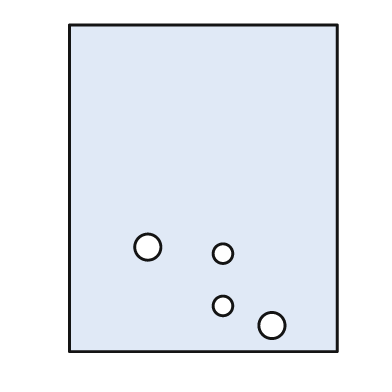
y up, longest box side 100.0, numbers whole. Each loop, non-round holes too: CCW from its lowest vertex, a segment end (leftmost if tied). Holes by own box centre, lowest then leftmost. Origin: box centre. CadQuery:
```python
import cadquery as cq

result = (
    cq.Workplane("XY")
    .moveTo(-41.0, -50.0)
    .lineTo(41.0, -50.0)
    .lineTo(41.0, 50.0)
    .lineTo(-41.0, 50.0)
    .close()
    .moveTo(21.0, -42.0)
    .circle(4.0)
    .moveTo(6.0, -36.0)
    .circle(3.0)
    .moveTo(6.0, -20.0)
    .circle(3.0)
    .moveTo(-17.0, -18.0)
    .circle(4.0)
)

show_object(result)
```